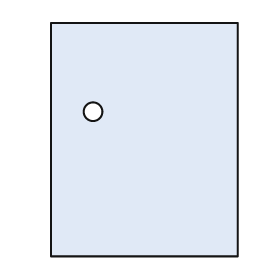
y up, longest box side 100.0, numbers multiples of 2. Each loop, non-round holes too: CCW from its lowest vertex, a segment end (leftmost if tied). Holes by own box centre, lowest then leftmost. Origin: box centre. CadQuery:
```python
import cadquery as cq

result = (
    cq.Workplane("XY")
    .moveTo(-40.0, -50.0)
    .lineTo(40.0, -50.0)
    .lineTo(40.0, 50.0)
    .lineTo(-40.0, 50.0)
    .close()
    .moveTo(-22.0, 12.0)
    .circle(4.0)
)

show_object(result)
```